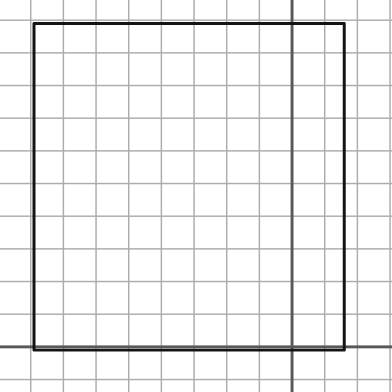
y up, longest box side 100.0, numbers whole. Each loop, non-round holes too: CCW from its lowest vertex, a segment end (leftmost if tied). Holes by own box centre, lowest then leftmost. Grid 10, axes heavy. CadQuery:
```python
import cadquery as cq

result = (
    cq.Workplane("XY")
    .moveTo(-79.0, -1.0)
    .lineTo(16.0, -1.0)
    .lineTo(16.0, 99.0)
    .lineTo(-79.0, 99.0)
    .close()
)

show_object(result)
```